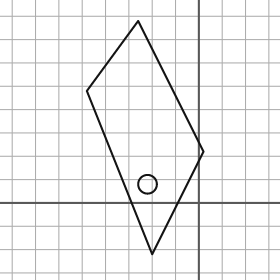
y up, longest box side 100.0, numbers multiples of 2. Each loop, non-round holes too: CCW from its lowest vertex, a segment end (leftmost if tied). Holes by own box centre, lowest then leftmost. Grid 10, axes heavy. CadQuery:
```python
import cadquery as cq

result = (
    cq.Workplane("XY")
    .moveTo(-20.0, -22.0)
    .lineTo(2.0, 22.0)
    .lineTo(-26.0, 78.0)
    .lineTo(-48.0, 48.0)
    .close()
    .moveTo(-22.0, 8.0)
    .circle(4.0)
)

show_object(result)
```